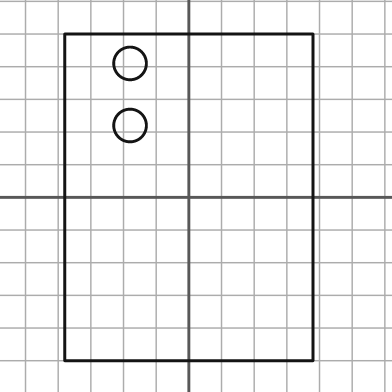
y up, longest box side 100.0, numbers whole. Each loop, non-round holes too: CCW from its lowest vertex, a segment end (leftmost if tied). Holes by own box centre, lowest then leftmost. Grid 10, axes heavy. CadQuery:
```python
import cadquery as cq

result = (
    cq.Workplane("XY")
    .moveTo(-38.0, -50.0)
    .lineTo(38.0, -50.0)
    .lineTo(38.0, 50.0)
    .lineTo(-38.0, 50.0)
    .close()
    .moveTo(-18.0, 22.0)
    .circle(5.0)
    .moveTo(-18.0, 41.0)
    .circle(5.0)
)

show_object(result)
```